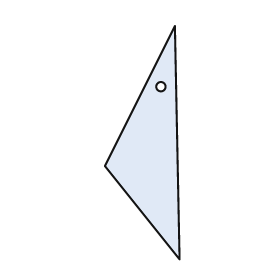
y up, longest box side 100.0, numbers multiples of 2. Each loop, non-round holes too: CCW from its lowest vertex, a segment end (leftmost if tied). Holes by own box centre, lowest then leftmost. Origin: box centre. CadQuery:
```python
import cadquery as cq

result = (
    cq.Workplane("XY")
    .moveTo(16.0, -50.0)
    .lineTo(14.0, 50.0)
    .lineTo(-16.0, -10.0)
    .close()
    .moveTo(8.0, 24.0)
    .circle(2.0)
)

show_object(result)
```